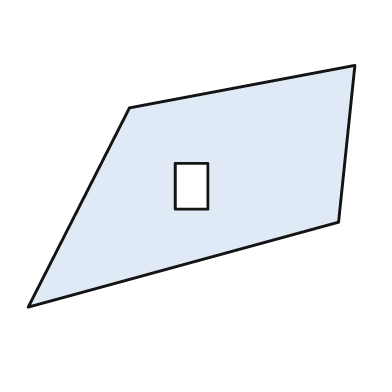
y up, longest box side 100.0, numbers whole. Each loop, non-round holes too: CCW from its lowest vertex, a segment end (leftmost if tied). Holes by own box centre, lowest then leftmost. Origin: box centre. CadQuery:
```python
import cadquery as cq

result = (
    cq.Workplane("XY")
    .moveTo(-50.0, -37.0)
    .lineTo(45.0, -11.0)
    .lineTo(50.0, 37.0)
    .lineTo(-19.0, 24.0)
    .close()
    .moveTo(-5.0, -7.0)
    .lineTo(5.0, -7.0)
    .lineTo(5.0, 7.0)
    .lineTo(-5.0, 7.0)
    .close()
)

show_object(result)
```